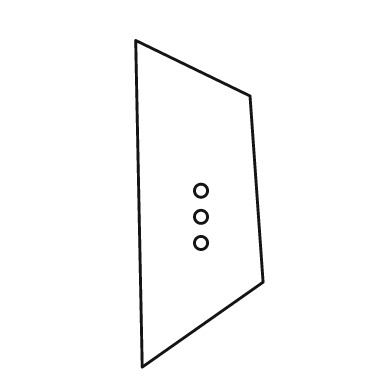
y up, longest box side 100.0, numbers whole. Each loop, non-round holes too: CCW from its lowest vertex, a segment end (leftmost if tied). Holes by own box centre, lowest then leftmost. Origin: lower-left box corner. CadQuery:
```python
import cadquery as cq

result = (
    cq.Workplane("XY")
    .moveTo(2.0, 0.0)
    .lineTo(39.0, 26.0)
    .lineTo(35.0, 83.0)
    .lineTo(0.0, 100.0)
    .close()
    .moveTo(20.0, 38.0)
    .circle(2.0)
    .moveTo(20.0, 46.0)
    .circle(2.0)
    .moveTo(20.0, 54.0)
    .circle(2.0)
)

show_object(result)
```